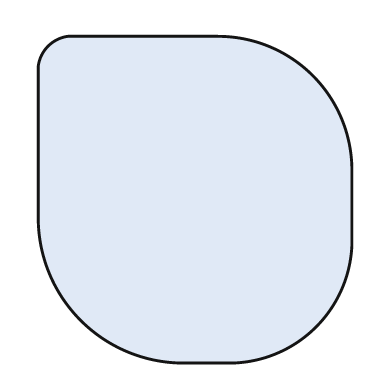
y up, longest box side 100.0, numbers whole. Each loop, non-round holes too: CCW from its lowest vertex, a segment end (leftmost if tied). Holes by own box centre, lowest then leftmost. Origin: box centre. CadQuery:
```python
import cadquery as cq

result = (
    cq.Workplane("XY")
    .moveTo(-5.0, -50.0)
    .lineTo(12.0, -50.0)
    .threePointArc((37.0, -39.0), (48.0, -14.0))
    .lineTo(48.0, 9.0)
    .threePointArc((36.0, 38.0), (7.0, 50.0))
    .lineTo(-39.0, 50.0)
    .threePointArc((-45.0, 47.0), (-48.0, 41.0))
    .lineTo(-48.0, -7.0)
    .threePointArc((-35.0, -37.0), (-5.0, -50.0))
    .close()
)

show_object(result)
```